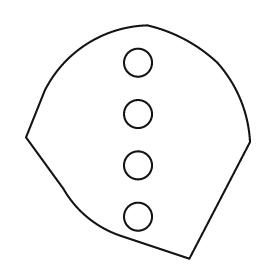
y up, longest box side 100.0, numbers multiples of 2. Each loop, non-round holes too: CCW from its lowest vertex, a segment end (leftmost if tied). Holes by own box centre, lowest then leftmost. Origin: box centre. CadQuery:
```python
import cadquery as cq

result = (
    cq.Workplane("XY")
    .moveTo(22.0, -50.0)
    .lineTo(48.0, 0.0)
    .threePointArc((44.0, 18.0), (34.0, 34.0))
    .threePointArc((20.0, 44.0), (4.0, 50.0))
    .threePointArc((-22.0, 42.0), (-40.0, 22.0))
    .lineTo(-48.0, 2.0)
    .lineTo(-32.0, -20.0)
    .threePointArc((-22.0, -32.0), (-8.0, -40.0))
    .close()
    .moveTo(0.0, -32.0)
    .circle(6.0)
    .moveTo(0.0, -10.0)
    .circle(6.0)
    .moveTo(0.0, 12.0)
    .circle(6.0)
    .moveTo(0.0, 34.0)
    .circle(6.0)
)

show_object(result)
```